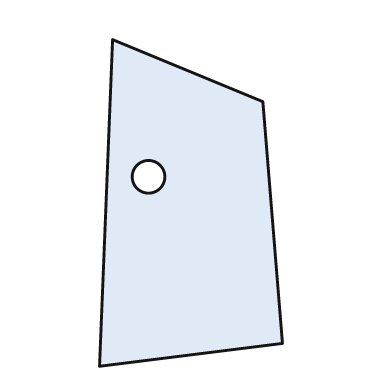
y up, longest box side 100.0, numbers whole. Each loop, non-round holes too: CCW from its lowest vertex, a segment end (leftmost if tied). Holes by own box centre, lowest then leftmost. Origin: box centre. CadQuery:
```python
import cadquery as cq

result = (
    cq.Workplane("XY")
    .moveTo(-28.0, -50.0)
    .lineTo(28.0, -43.0)
    .lineTo(22.0, 31.0)
    .lineTo(-24.0, 50.0)
    .close()
    .moveTo(-13.0, 8.0)
    .circle(5.0)
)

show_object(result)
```